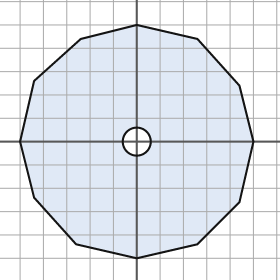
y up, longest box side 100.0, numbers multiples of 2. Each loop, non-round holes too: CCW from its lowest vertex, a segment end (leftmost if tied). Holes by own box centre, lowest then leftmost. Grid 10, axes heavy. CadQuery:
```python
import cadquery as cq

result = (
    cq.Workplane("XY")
    .moveTo(0.0, -50.0)
    .lineTo(26.0, -44.0)
    .lineTo(44.0, -26.0)
    .lineTo(50.0, 0.0)
    .lineTo(44.0, 24.0)
    .lineTo(26.0, 44.0)
    .lineTo(0.0, 50.0)
    .lineTo(-24.0, 44.0)
    .lineTo(-44.0, 26.0)
    .lineTo(-50.0, 0.0)
    .lineTo(-44.0, -24.0)
    .lineTo(-26.0, -44.0)
    .close()
    .moveTo(0.0, 0.0)
    .circle(6.0)
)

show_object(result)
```